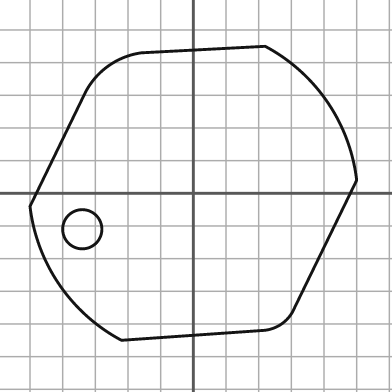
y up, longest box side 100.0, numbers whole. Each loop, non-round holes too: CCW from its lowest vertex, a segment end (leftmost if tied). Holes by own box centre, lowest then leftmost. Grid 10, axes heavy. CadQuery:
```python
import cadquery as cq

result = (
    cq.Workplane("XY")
    .moveTo(-22.0, -45.0)
    .lineTo(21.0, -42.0)
    .threePointArc((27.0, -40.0), (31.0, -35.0))
    .lineTo(50.0, 4.0)
    .threePointArc((41.0, 28.0), (22.0, 45.0))
    .lineTo(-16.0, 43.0)
    .threePointArc((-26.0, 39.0), (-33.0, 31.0))
    .lineTo(-50.0, -4.0)
    .threePointArc((-41.0, -28.0), (-22.0, -45.0))
    .close()
    .moveTo(-34.0, -11.0)
    .circle(6.0)
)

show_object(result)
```